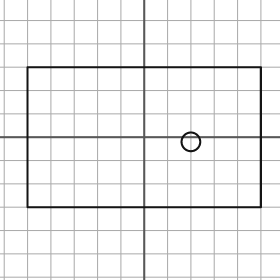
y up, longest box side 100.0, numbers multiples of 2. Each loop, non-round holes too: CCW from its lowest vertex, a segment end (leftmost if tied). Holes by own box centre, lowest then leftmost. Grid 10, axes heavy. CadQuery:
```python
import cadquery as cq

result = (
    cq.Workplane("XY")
    .moveTo(-50.0, -30.0)
    .lineTo(50.0, -30.0)
    .lineTo(50.0, 30.0)
    .lineTo(-50.0, 30.0)
    .close()
    .moveTo(20.0, -2.0)
    .circle(4.0)
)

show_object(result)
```